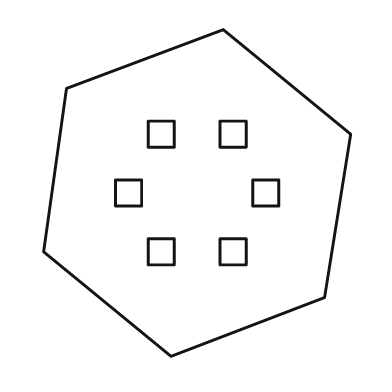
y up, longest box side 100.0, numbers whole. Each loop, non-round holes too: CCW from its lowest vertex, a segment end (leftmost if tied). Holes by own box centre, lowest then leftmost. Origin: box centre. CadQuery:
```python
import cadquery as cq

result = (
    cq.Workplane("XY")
    .moveTo(-8.0, -50.0)
    .lineTo(39.0, -32.0)
    .lineTo(47.0, 18.0)
    .lineTo(8.0, 50.0)
    .lineTo(-40.0, 32.0)
    .lineTo(-47.0, -18.0)
    .close()
    .moveTo(-15.0, -22.0)
    .lineTo(-7.0, -22.0)
    .lineTo(-7.0, -14.0)
    .lineTo(-15.0, -14.0)
    .close()
    .moveTo(7.0, -22.0)
    .lineTo(15.0, -22.0)
    .lineTo(15.0, -14.0)
    .lineTo(7.0, -14.0)
    .close()
    .moveTo(-25.0, -4.0)
    .lineTo(-17.0, -4.0)
    .lineTo(-17.0, 4.0)
    .lineTo(-25.0, 4.0)
    .close()
    .moveTo(17.0, -4.0)
    .lineTo(25.0, -4.0)
    .lineTo(25.0, 4.0)
    .lineTo(17.0, 4.0)
    .close()
    .moveTo(-15.0, 14.0)
    .lineTo(-7.0, 14.0)
    .lineTo(-7.0, 22.0)
    .lineTo(-15.0, 22.0)
    .close()
    .moveTo(7.0, 14.0)
    .lineTo(15.0, 14.0)
    .lineTo(15.0, 22.0)
    .lineTo(7.0, 22.0)
    .close()
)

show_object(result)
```